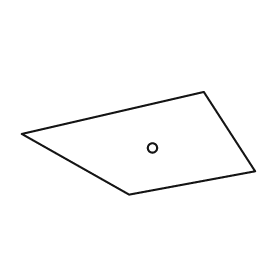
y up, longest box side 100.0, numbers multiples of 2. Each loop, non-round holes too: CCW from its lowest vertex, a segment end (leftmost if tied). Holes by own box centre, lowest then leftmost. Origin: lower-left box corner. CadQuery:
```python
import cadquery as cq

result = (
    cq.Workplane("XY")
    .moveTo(46.0, 0.0)
    .lineTo(100.0, 10.0)
    .lineTo(78.0, 44.0)
    .lineTo(0.0, 26.0)
    .close()
    .moveTo(56.0, 20.0)
    .circle(2.0)
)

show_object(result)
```